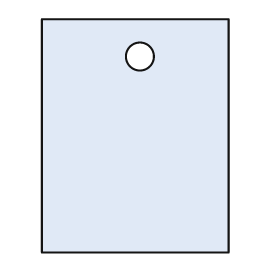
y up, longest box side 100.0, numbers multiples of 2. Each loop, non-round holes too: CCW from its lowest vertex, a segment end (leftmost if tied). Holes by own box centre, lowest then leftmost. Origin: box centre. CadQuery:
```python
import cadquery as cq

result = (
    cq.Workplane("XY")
    .moveTo(-40.0, -50.0)
    .lineTo(40.0, -50.0)
    .lineTo(40.0, 50.0)
    .lineTo(-40.0, 50.0)
    .close()
    .moveTo(2.0, 34.0)
    .circle(6.0)
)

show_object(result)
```